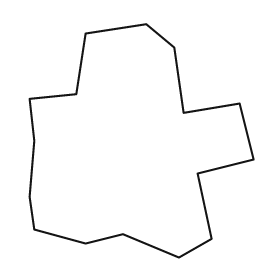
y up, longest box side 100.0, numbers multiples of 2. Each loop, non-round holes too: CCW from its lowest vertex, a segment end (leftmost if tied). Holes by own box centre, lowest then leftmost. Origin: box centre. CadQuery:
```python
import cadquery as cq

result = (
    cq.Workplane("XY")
    .moveTo(16.0, -50.0)
    .lineTo(30.0, -42.0)
    .lineTo(24.0, -14.0)
    .lineTo(48.0, -8.0)
    .lineTo(42.0, 16.0)
    .lineTo(18.0, 12.0)
    .lineTo(14.0, 40.0)
    .lineTo(2.0, 50.0)
    .lineTo(-24.0, 46.0)
    .lineTo(-28.0, 20.0)
    .lineTo(-48.0, 18.0)
    .lineTo(-46.0, 0.0)
    .lineTo(-48.0, -24.0)
    .lineTo(-46.0, -38.0)
    .lineTo(-24.0, -44.0)
    .lineTo(-8.0, -40.0)
    .close()
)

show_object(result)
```